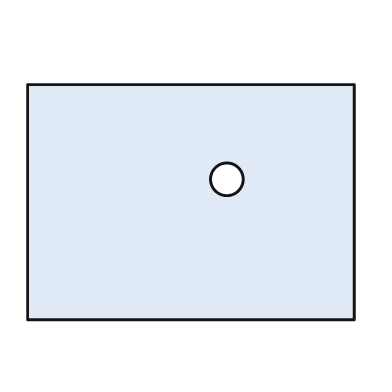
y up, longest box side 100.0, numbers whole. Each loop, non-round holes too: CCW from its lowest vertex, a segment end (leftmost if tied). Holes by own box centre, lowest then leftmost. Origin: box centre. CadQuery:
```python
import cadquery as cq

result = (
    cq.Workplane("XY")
    .moveTo(-50.0, -36.0)
    .lineTo(50.0, -36.0)
    .lineTo(50.0, 36.0)
    .lineTo(-50.0, 36.0)
    .close()
    .moveTo(11.0, 7.0)
    .circle(5.0)
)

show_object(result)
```